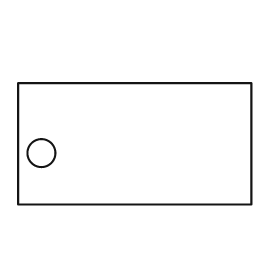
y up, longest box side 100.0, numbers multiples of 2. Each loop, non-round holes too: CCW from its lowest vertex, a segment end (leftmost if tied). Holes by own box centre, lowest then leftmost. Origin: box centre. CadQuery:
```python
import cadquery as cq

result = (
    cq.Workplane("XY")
    .moveTo(-50.0, -26.0)
    .lineTo(50.0, -26.0)
    .lineTo(50.0, 26.0)
    .lineTo(-50.0, 26.0)
    .close()
    .moveTo(-40.0, -4.0)
    .circle(6.0)
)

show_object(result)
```